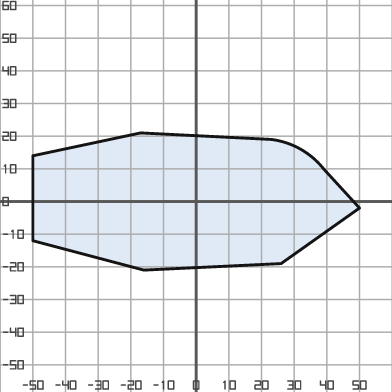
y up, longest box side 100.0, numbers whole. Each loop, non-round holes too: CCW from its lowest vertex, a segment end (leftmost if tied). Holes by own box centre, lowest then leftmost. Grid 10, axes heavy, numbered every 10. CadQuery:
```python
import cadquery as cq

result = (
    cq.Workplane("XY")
    .moveTo(-16.0, -21.0)
    .lineTo(26.0, -19.0)
    .lineTo(50.0, -2.0)
    .lineTo(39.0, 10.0)
    .threePointArc((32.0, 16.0), (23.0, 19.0))
    .lineTo(-17.0, 21.0)
    .lineTo(-50.0, 14.0)
    .lineTo(-50.0, -12.0)
    .close()
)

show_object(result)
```